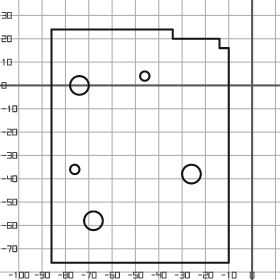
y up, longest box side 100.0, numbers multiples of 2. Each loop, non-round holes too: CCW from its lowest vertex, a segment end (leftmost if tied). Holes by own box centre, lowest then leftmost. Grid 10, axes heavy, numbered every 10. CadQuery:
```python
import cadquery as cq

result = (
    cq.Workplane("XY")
    .moveTo(-86.0, -76.0)
    .lineTo(-10.0, -76.0)
    .lineTo(-10.0, 16.0)
    .lineTo(-14.0, 16.0)
    .lineTo(-14.0, 20.0)
    .lineTo(-34.0, 20.0)
    .lineTo(-34.0, 24.0)
    .lineTo(-86.0, 24.0)
    .close()
    .moveTo(-68.0, -58.0)
    .circle(4.0)
    .moveTo(-26.0, -38.0)
    .circle(4.0)
    .moveTo(-76.0, -36.0)
    .circle(2.0)
    .moveTo(-74.0, 0.0)
    .circle(4.0)
    .moveTo(-46.0, 4.0)
    .circle(2.0)
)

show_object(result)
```